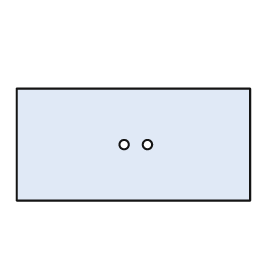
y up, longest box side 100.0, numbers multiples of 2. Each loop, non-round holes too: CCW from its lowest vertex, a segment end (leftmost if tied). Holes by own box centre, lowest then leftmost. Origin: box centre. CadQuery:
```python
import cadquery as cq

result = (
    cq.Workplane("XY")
    .moveTo(-50.0, -24.0)
    .lineTo(50.0, -24.0)
    .lineTo(50.0, 24.0)
    .lineTo(-50.0, 24.0)
    .close()
    .moveTo(-4.0, 0.0)
    .circle(2.0)
    .moveTo(6.0, 0.0)
    .circle(2.0)
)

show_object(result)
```